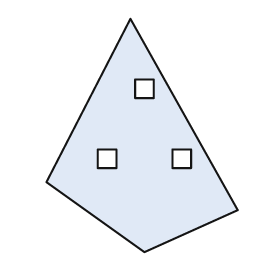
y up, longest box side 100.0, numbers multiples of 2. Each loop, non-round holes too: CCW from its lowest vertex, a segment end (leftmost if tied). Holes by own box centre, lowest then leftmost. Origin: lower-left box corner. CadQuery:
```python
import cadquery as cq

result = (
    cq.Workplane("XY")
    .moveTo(42.0, 0.0)
    .lineTo(82.0, 18.0)
    .lineTo(36.0, 100.0)
    .lineTo(0.0, 30.0)
    .close()
    .moveTo(22.0, 36.0)
    .lineTo(30.0, 36.0)
    .lineTo(30.0, 44.0)
    .lineTo(22.0, 44.0)
    .close()
    .moveTo(54.0, 36.0)
    .lineTo(62.0, 36.0)
    .lineTo(62.0, 44.0)
    .lineTo(54.0, 44.0)
    .close()
    .moveTo(38.0, 66.0)
    .lineTo(46.0, 66.0)
    .lineTo(46.0, 74.0)
    .lineTo(38.0, 74.0)
    .close()
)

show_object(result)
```